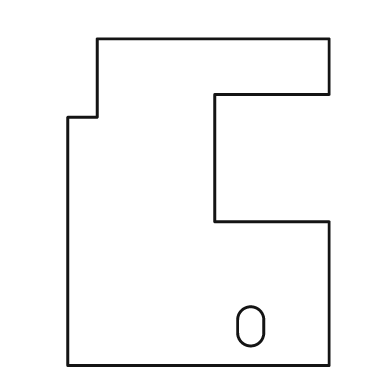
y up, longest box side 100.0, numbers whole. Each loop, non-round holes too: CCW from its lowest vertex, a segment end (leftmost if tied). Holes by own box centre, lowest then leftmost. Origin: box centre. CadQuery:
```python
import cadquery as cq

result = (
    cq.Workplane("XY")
    .moveTo(-40.0, -50.0)
    .lineTo(40.0, -50.0)
    .lineTo(40.0, -6.0)
    .lineTo(5.0, -6.0)
    .lineTo(5.0, 33.0)
    .lineTo(40.0, 33.0)
    .lineTo(40.0, 50.0)
    .lineTo(-31.0, 50.0)
    .lineTo(-31.0, 26.0)
    .lineTo(-40.0, 26.0)
    .close()
    .moveTo(12.0, -40.0)
    .threePointArc((16.0, -44.0), (20.0, -40.0))
    .lineTo(20.0, -36.0)
    .threePointArc((16.0, -32.0), (12.0, -36.0))
    .close()
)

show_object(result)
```